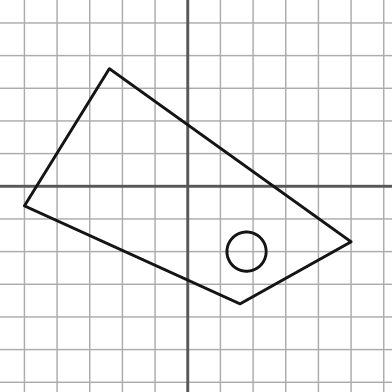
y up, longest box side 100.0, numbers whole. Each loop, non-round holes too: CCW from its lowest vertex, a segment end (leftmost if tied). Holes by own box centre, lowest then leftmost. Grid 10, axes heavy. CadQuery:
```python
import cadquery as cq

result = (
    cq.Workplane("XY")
    .moveTo(16.0, -36.0)
    .lineTo(50.0, -17.0)
    .lineTo(-24.0, 36.0)
    .lineTo(-50.0, -6.0)
    .close()
    .moveTo(18.0, -20.0)
    .circle(6.0)
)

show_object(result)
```